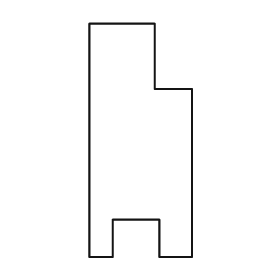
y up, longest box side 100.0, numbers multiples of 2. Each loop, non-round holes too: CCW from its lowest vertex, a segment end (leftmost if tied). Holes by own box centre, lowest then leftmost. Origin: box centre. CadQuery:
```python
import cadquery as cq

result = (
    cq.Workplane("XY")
    .moveTo(-22.0, -50.0)
    .lineTo(-12.0, -50.0)
    .lineTo(-12.0, -34.0)
    .lineTo(8.0, -34.0)
    .lineTo(8.0, -50.0)
    .lineTo(22.0, -50.0)
    .lineTo(22.0, 22.0)
    .lineTo(6.0, 22.0)
    .lineTo(6.0, 50.0)
    .lineTo(-22.0, 50.0)
    .close()
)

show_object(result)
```